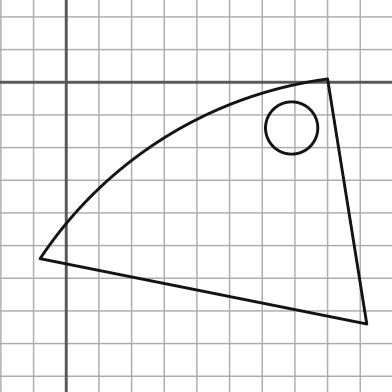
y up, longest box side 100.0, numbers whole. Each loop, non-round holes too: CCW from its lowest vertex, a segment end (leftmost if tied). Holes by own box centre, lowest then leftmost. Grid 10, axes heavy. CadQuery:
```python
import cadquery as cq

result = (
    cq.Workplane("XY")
    .moveTo(92.0, -74.0)
    .lineTo(80.0, 1.0)
    .threePointArc((30.0, -17.0), (-8.0, -54.0))
    .close()
    .moveTo(69.0, -14.0)
    .circle(8.0)
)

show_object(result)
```